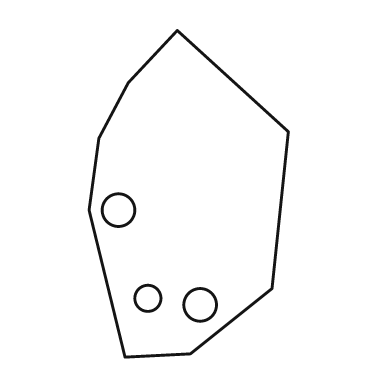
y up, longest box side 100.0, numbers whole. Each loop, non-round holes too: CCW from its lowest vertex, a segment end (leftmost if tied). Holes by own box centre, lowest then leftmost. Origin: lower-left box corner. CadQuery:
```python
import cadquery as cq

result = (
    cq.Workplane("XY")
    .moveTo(11.0, 0.0)
    .lineTo(31.0, 1.0)
    .lineTo(56.0, 21.0)
    .lineTo(61.0, 69.0)
    .lineTo(27.0, 100.0)
    .lineTo(12.0, 84.0)
    .lineTo(3.0, 67.0)
    .lineTo(0.0, 45.0)
    .close()
    .moveTo(34.0, 16.0)
    .circle(5.0)
    .moveTo(18.0, 18.0)
    .circle(4.0)
    .moveTo(9.0, 45.0)
    .circle(5.0)
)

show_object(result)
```